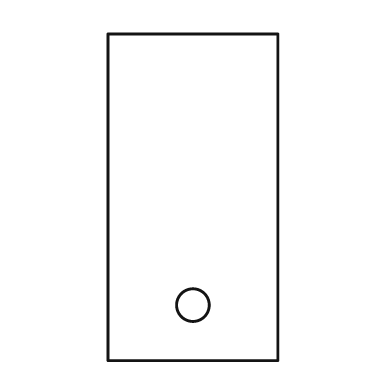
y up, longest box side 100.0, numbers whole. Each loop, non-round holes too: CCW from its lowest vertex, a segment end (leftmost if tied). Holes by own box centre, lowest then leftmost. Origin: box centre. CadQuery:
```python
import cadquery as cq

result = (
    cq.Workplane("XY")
    .moveTo(-26.0, -50.0)
    .lineTo(26.0, -50.0)
    .lineTo(26.0, 50.0)
    .lineTo(-26.0, 50.0)
    .close()
    .moveTo(0.0, -33.0)
    .circle(5.0)
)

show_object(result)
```